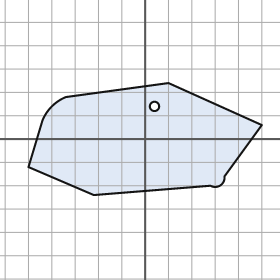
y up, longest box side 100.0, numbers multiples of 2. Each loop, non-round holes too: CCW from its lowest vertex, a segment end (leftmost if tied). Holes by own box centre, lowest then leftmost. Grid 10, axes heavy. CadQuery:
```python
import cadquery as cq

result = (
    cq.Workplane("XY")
    .moveTo(-22.0, -24.0)
    .lineTo(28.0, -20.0)
    .threePointArc((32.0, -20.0), (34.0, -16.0))
    .lineTo(50.0, 6.0)
    .lineTo(10.0, 24.0)
    .lineTo(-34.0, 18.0)
    .threePointArc((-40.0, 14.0), (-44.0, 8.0))
    .lineTo(-50.0, -12.0)
    .close()
    .moveTo(4.0, 14.0)
    .circle(2.0)
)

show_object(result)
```